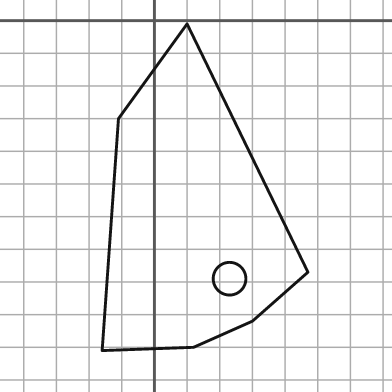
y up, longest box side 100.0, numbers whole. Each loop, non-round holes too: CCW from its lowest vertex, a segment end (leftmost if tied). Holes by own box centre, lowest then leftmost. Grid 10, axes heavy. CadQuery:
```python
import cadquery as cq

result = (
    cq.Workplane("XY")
    .moveTo(-16.0, -101.0)
    .lineTo(12.0, -100.0)
    .lineTo(30.0, -92.0)
    .lineTo(47.0, -77.0)
    .lineTo(10.0, -1.0)
    .lineTo(-11.0, -30.0)
    .close()
    .moveTo(23.0, -79.0)
    .circle(5.0)
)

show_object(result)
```